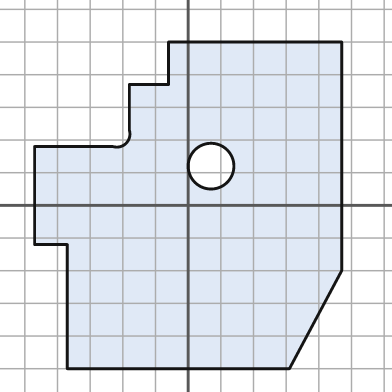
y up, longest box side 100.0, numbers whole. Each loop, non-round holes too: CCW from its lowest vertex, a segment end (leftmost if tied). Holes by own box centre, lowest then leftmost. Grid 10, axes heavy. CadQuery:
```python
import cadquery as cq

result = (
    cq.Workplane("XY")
    .moveTo(-37.0, -50.0)
    .lineTo(31.0, -50.0)
    .lineTo(47.0, -20.0)
    .lineTo(47.0, 50.0)
    .lineTo(-6.0, 50.0)
    .lineTo(-6.0, 37.0)
    .lineTo(-18.0, 37.0)
    .lineTo(-18.0, 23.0)
    .threePointArc((-19.0, 19.0), (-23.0, 18.0))
    .lineTo(-47.0, 18.0)
    .lineTo(-47.0, -12.0)
    .lineTo(-37.0, -12.0)
    .close()
    .moveTo(7.0, 12.0)
    .circle(7.0)
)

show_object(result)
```